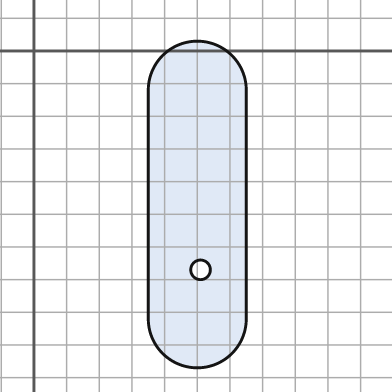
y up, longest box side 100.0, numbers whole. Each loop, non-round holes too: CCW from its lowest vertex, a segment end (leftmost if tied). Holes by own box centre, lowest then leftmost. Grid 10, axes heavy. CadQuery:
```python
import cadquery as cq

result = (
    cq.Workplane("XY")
    .moveTo(35.0, -82.0)
    .threePointArc((50.0, -97.0), (65.0, -82.0))
    .lineTo(65.0, -12.0)
    .threePointArc((50.0, 3.0), (35.0, -12.0))
    .close()
    .moveTo(51.0, -67.0)
    .circle(3.0)
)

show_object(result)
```